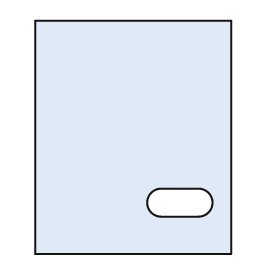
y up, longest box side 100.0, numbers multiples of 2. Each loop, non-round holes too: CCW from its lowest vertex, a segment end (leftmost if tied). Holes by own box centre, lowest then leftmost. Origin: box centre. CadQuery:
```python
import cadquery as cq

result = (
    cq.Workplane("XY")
    .moveTo(-42.0, -50.0)
    .lineTo(42.0, -50.0)
    .lineTo(42.0, 50.0)
    .lineTo(-42.0, 50.0)
    .close()
    .moveTo(12.0, -34.0)
    .lineTo(28.0, -34.0)
    .threePointArc((34.0, -28.0), (28.0, -22.0))
    .lineTo(12.0, -22.0)
    .threePointArc((6.0, -28.0), (12.0, -34.0))
    .close()
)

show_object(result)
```